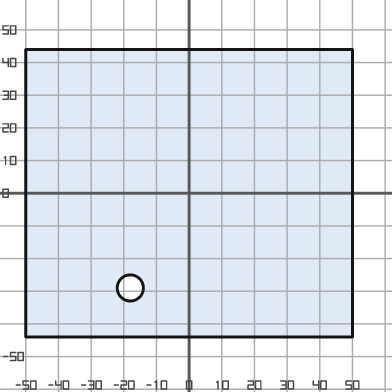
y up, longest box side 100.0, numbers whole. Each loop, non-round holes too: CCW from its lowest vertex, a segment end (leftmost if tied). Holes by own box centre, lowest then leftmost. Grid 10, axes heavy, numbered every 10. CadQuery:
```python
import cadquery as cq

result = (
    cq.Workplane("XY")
    .moveTo(-50.0, -44.0)
    .lineTo(50.0, -44.0)
    .lineTo(50.0, 44.0)
    .lineTo(-50.0, 44.0)
    .close()
    .moveTo(-18.0, -29.0)
    .circle(4.0)
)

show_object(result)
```